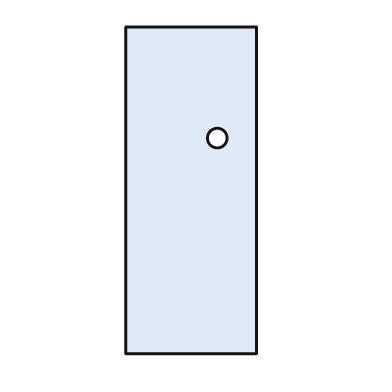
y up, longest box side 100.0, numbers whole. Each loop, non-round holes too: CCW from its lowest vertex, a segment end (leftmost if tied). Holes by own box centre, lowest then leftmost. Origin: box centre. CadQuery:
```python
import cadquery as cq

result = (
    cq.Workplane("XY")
    .moveTo(-20.0, -50.0)
    .lineTo(20.0, -50.0)
    .lineTo(20.0, 50.0)
    .lineTo(-20.0, 50.0)
    .close()
    .moveTo(8.0, 16.0)
    .circle(3.0)
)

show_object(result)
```